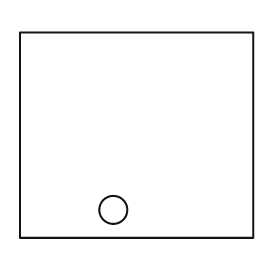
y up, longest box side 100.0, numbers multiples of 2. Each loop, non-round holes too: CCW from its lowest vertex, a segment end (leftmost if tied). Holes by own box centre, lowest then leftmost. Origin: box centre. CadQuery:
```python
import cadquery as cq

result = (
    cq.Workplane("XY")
    .moveTo(-50.0, -44.0)
    .lineTo(50.0, -44.0)
    .lineTo(50.0, 44.0)
    .lineTo(-50.0, 44.0)
    .close()
    .moveTo(-10.0, -32.0)
    .circle(6.0)
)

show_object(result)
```